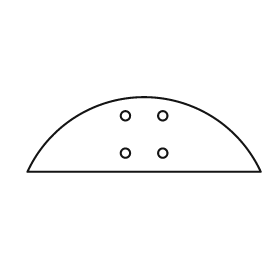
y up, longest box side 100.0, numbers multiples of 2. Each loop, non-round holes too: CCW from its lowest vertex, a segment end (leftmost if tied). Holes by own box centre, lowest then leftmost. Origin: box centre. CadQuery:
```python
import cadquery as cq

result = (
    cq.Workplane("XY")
    .moveTo(-50.0, -16.0)
    .lineTo(50.0, -16.0)
    .threePointArc((0.0, 16.0), (-50.0, -16.0))
    .close()
    .moveTo(-8.0, -8.0)
    .circle(2.0)
    .moveTo(8.0, -8.0)
    .circle(2.0)
    .moveTo(-8.0, 8.0)
    .circle(2.0)
    .moveTo(8.0, 8.0)
    .circle(2.0)
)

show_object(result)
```